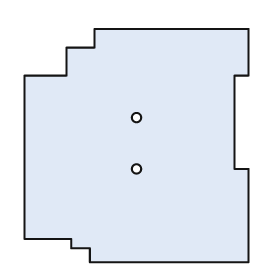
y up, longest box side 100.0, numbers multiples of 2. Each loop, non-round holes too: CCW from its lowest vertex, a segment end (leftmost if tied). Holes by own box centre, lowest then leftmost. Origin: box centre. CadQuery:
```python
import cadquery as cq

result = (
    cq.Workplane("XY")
    .moveTo(-20.0, -50.0)
    .lineTo(48.0, -50.0)
    .lineTo(48.0, -10.0)
    .lineTo(42.0, -10.0)
    .lineTo(42.0, 30.0)
    .lineTo(48.0, 30.0)
    .lineTo(48.0, 50.0)
    .lineTo(-18.0, 50.0)
    .lineTo(-18.0, 42.0)
    .lineTo(-30.0, 42.0)
    .lineTo(-30.0, 30.0)
    .lineTo(-48.0, 30.0)
    .lineTo(-48.0, -40.0)
    .lineTo(-28.0, -40.0)
    .lineTo(-28.0, -44.0)
    .lineTo(-20.0, -44.0)
    .close()
    .moveTo(0.0, -10.0)
    .circle(2.0)
    .moveTo(0.0, 12.0)
    .circle(2.0)
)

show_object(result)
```